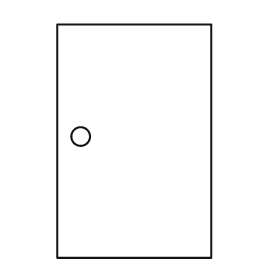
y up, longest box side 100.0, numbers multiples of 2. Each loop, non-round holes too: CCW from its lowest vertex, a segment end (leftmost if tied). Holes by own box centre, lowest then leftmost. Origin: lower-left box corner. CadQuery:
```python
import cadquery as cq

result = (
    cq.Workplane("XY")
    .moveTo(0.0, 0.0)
    .lineTo(66.0, 0.0)
    .lineTo(66.0, 100.0)
    .lineTo(0.0, 100.0)
    .close()
    .moveTo(10.0, 52.0)
    .circle(4.0)
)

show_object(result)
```